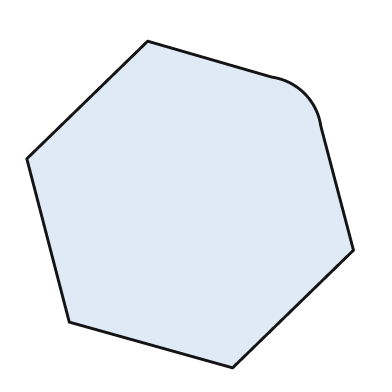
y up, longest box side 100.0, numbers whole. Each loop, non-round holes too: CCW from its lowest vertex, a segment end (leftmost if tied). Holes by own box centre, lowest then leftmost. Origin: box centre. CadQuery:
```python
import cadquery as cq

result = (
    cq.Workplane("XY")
    .moveTo(13.0, -50.0)
    .lineTo(50.0, -14.0)
    .lineTo(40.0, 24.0)
    .threePointArc((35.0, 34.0), (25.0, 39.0))
    .lineTo(-13.0, 50.0)
    .lineTo(-50.0, 14.0)
    .lineTo(-37.0, -36.0)
    .close()
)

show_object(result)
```